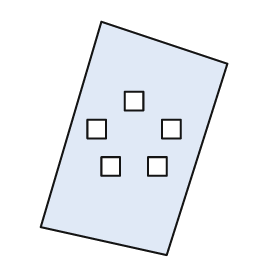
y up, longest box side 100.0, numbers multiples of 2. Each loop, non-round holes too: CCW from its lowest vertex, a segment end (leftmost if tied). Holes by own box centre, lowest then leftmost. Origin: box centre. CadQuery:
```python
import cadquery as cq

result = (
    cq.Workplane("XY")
    .moveTo(14.0, -50.0)
    .lineTo(40.0, 32.0)
    .lineTo(-14.0, 50.0)
    .lineTo(-40.0, -38.0)
    .close()
    .moveTo(-14.0, -16.0)
    .lineTo(-6.0, -16.0)
    .lineTo(-6.0, -8.0)
    .lineTo(-14.0, -8.0)
    .close()
    .moveTo(6.0, -16.0)
    .lineTo(14.0, -16.0)
    .lineTo(14.0, -8.0)
    .lineTo(6.0, -8.0)
    .close()
    .moveTo(-20.0, 0.0)
    .lineTo(-12.0, 0.0)
    .lineTo(-12.0, 8.0)
    .lineTo(-20.0, 8.0)
    .close()
    .moveTo(12.0, 0.0)
    .lineTo(20.0, 0.0)
    .lineTo(20.0, 8.0)
    .lineTo(12.0, 8.0)
    .close()
    .moveTo(-4.0, 12.0)
    .lineTo(4.0, 12.0)
    .lineTo(4.0, 20.0)
    .lineTo(-4.0, 20.0)
    .close()
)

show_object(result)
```